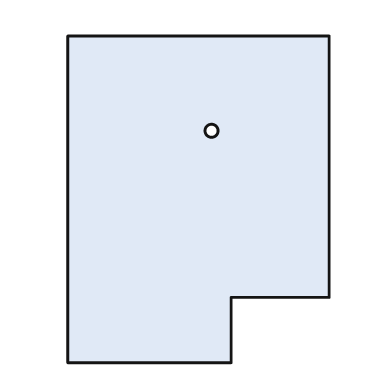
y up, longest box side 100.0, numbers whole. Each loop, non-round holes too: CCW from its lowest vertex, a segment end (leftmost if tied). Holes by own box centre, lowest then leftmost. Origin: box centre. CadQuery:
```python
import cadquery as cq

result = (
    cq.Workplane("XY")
    .moveTo(-40.0, -50.0)
    .lineTo(10.0, -50.0)
    .lineTo(10.0, -30.0)
    .lineTo(40.0, -30.0)
    .lineTo(40.0, 50.0)
    .lineTo(-40.0, 50.0)
    .close()
    .moveTo(4.0, 21.0)
    .circle(2.0)
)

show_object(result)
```